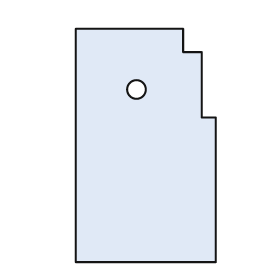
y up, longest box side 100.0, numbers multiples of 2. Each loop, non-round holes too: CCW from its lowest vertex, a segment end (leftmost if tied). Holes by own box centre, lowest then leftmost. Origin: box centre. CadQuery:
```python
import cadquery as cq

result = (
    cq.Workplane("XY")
    .moveTo(-30.0, -50.0)
    .lineTo(30.0, -50.0)
    .lineTo(30.0, 12.0)
    .lineTo(24.0, 12.0)
    .lineTo(24.0, 40.0)
    .lineTo(16.0, 40.0)
    .lineTo(16.0, 50.0)
    .lineTo(-30.0, 50.0)
    .close()
    .moveTo(-4.0, 24.0)
    .circle(4.0)
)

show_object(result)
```